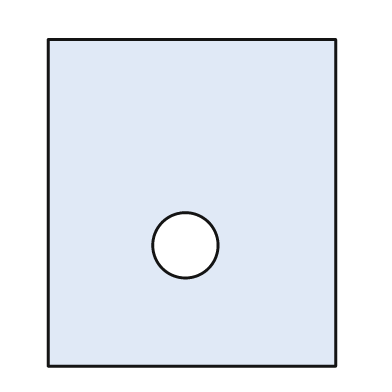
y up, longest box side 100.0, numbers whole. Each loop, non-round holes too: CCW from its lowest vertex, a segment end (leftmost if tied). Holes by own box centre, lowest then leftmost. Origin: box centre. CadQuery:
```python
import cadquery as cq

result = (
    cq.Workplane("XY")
    .moveTo(-44.0, -50.0)
    .lineTo(44.0, -50.0)
    .lineTo(44.0, 50.0)
    .lineTo(-44.0, 50.0)
    .close()
    .moveTo(-2.0, -13.0)
    .circle(10.0)
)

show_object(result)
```